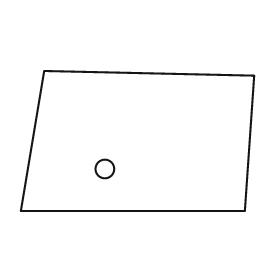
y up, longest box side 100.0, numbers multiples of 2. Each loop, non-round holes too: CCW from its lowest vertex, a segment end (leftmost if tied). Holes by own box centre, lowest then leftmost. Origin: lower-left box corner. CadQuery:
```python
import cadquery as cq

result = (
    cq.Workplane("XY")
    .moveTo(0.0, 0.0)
    .lineTo(96.0, 0.0)
    .lineTo(100.0, 58.0)
    .lineTo(10.0, 60.0)
    .close()
    .moveTo(36.0, 18.0)
    .circle(4.0)
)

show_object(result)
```